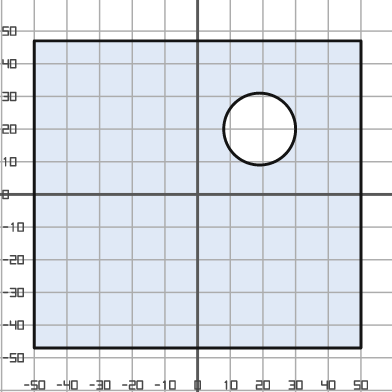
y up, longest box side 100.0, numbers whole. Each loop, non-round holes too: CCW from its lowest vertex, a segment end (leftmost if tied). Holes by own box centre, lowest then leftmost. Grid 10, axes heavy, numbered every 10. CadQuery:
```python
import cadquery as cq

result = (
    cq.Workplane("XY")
    .moveTo(-50.0, -47.0)
    .lineTo(50.0, -47.0)
    .lineTo(50.0, 47.0)
    .lineTo(-50.0, 47.0)
    .close()
    .moveTo(19.0, 20.0)
    .circle(11.0)
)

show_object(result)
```